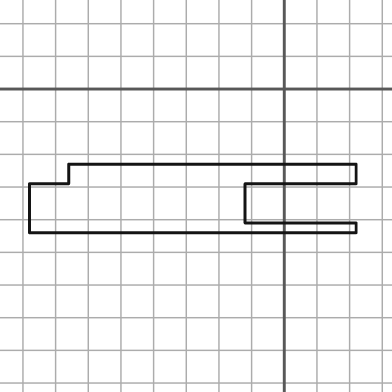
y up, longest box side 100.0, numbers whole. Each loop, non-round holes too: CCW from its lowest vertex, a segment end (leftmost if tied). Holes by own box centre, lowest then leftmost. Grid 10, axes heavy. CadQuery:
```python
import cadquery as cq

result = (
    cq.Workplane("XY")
    .moveTo(-78.0, -44.0)
    .lineTo(22.0, -44.0)
    .lineTo(22.0, -41.0)
    .lineTo(-12.0, -41.0)
    .lineTo(-12.0, -29.0)
    .lineTo(22.0, -29.0)
    .lineTo(22.0, -23.0)
    .lineTo(-66.0, -23.0)
    .lineTo(-66.0, -29.0)
    .lineTo(-78.0, -29.0)
    .close()
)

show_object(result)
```